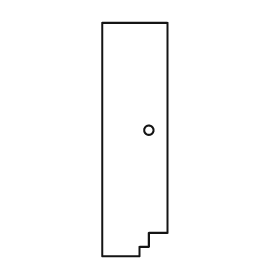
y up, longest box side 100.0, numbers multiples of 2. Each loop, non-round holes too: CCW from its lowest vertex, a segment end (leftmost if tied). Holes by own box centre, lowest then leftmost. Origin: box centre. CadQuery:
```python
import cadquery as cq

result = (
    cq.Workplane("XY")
    .moveTo(-14.0, -50.0)
    .lineTo(2.0, -50.0)
    .lineTo(2.0, -46.0)
    .lineTo(6.0, -46.0)
    .lineTo(6.0, -40.0)
    .lineTo(14.0, -40.0)
    .lineTo(14.0, 50.0)
    .lineTo(-14.0, 50.0)
    .close()
    .moveTo(6.0, 4.0)
    .circle(2.0)
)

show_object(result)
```